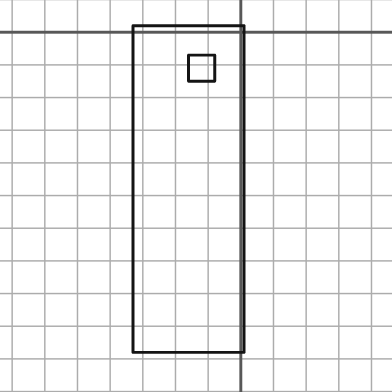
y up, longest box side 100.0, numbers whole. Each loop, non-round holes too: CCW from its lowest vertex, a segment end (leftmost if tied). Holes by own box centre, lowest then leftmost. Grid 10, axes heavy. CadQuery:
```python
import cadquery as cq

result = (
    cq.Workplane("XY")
    .moveTo(-33.0, -98.0)
    .lineTo(1.0, -98.0)
    .lineTo(1.0, 2.0)
    .lineTo(-33.0, 2.0)
    .close()
    .moveTo(-16.0, -15.0)
    .lineTo(-8.0, -15.0)
    .lineTo(-8.0, -7.0)
    .lineTo(-16.0, -7.0)
    .close()
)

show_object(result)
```